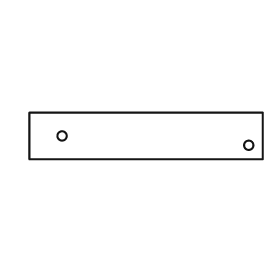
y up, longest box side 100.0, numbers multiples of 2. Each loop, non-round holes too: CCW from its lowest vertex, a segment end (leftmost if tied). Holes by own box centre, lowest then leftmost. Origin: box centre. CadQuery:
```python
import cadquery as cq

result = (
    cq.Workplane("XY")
    .moveTo(-50.0, -10.0)
    .lineTo(50.0, -10.0)
    .lineTo(50.0, 10.0)
    .lineTo(-50.0, 10.0)
    .close()
    .moveTo(44.0, -4.0)
    .circle(2.0)
    .moveTo(-36.0, 0.0)
    .circle(2.0)
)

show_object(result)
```